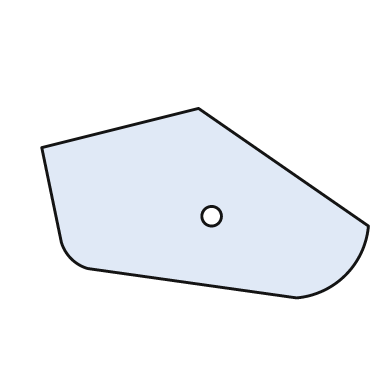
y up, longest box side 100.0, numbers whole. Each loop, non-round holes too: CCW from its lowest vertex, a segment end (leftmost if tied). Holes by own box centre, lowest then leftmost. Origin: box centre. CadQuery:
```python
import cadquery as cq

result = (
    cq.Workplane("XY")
    .moveTo(28.0, -29.0)
    .threePointArc((43.0, -22.0), (50.0, -7.0))
    .lineTo(-2.0, 29.0)
    .lineTo(-50.0, 17.0)
    .lineTo(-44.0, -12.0)
    .threePointArc((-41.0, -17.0), (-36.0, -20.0))
    .close()
    .moveTo(2.0, -4.0)
    .circle(3.0)
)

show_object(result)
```